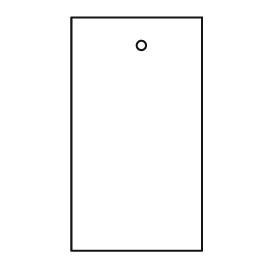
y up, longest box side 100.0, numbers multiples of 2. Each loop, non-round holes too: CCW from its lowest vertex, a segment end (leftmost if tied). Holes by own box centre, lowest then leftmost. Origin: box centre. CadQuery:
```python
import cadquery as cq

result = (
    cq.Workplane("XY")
    .moveTo(-28.0, -50.0)
    .lineTo(28.0, -50.0)
    .lineTo(28.0, 50.0)
    .lineTo(-28.0, 50.0)
    .close()
    .moveTo(2.0, 38.0)
    .circle(2.0)
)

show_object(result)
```